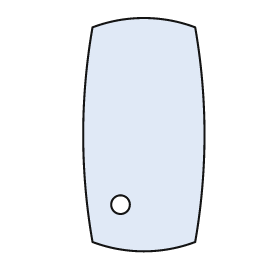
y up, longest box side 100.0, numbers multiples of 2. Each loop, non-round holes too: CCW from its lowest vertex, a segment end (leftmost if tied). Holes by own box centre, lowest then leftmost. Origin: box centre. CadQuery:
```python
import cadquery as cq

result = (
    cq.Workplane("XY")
    .moveTo(-22.0, -46.0)
    .threePointArc((0.0, -50.0), (22.0, -46.0))
    .threePointArc((26.0, 0.0), (22.0, 46.0))
    .threePointArc((0.0, 50.0), (-22.0, 46.0))
    .threePointArc((-26.0, 0.0), (-22.0, -46.0))
    .close()
    .moveTo(-10.0, -30.0)
    .circle(4.0)
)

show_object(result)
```